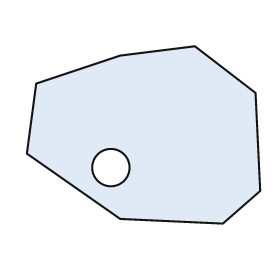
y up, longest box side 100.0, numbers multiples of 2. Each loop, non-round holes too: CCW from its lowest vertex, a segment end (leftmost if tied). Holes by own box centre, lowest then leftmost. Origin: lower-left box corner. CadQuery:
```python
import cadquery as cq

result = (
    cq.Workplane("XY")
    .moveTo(84.0, 0.0)
    .lineTo(100.0, 14.0)
    .lineTo(98.0, 56.0)
    .lineTo(72.0, 76.0)
    .lineTo(40.0, 72.0)
    .lineTo(4.0, 60.0)
    .lineTo(0.0, 30.0)
    .lineTo(40.0, 2.0)
    .close()
    .moveTo(36.0, 24.0)
    .circle(8.0)
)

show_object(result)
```